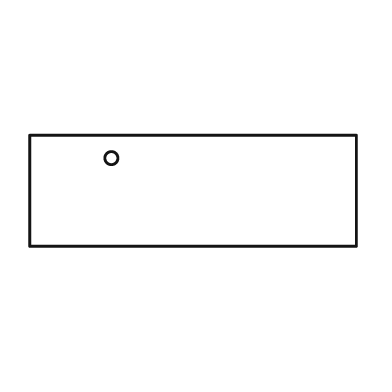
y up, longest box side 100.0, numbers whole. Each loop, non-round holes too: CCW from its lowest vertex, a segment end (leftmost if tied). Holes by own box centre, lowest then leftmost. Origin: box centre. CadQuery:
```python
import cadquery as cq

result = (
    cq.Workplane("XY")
    .moveTo(-50.0, -17.0)
    .lineTo(50.0, -17.0)
    .lineTo(50.0, 17.0)
    .lineTo(-50.0, 17.0)
    .close()
    .moveTo(-25.0, 10.0)
    .circle(2.0)
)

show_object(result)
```